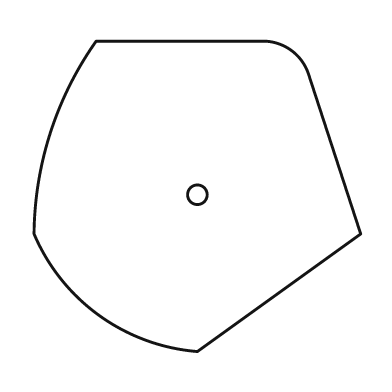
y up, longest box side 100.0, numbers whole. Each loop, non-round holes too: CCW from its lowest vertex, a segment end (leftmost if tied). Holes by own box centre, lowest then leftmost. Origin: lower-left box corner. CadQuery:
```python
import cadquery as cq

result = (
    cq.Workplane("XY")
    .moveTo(50.0, 0.0)
    .lineTo(100.0, 36.0)
    .lineTo(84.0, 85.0)
    .threePointArc((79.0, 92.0), (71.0, 95.0))
    .lineTo(19.0, 95.0)
    .threePointArc((5.0, 67.0), (0.0, 36.0))
    .threePointArc((20.0, 11.0), (50.0, 0.0))
    .close()
    .moveTo(50.0, 48.0)
    .circle(3.0)
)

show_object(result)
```